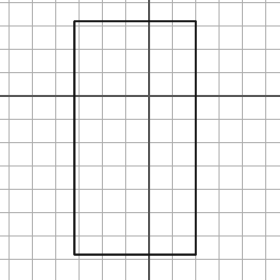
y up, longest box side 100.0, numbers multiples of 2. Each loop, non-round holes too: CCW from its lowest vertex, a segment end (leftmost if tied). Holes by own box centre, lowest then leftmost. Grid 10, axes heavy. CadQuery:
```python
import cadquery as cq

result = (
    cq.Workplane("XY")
    .moveTo(-32.0, -68.0)
    .lineTo(20.0, -68.0)
    .lineTo(20.0, 32.0)
    .lineTo(-32.0, 32.0)
    .close()
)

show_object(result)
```